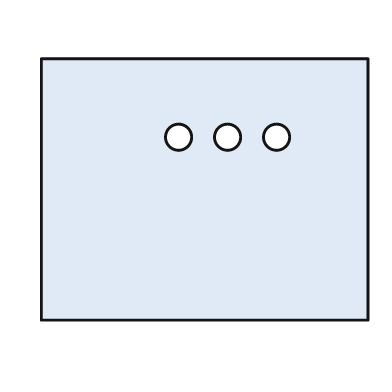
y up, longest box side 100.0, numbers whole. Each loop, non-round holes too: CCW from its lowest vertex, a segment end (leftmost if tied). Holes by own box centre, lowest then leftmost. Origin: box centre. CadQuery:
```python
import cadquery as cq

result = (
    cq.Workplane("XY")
    .moveTo(-50.0, -40.0)
    .lineTo(50.0, -40.0)
    .lineTo(50.0, 40.0)
    .lineTo(-50.0, 40.0)
    .close()
    .moveTo(-8.0, 16.0)
    .circle(4.0)
    .moveTo(7.0, 16.0)
    .circle(4.0)
    .moveTo(22.0, 16.0)
    .circle(4.0)
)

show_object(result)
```